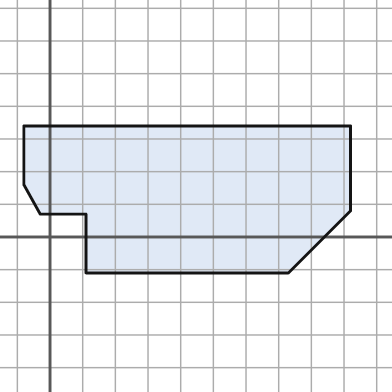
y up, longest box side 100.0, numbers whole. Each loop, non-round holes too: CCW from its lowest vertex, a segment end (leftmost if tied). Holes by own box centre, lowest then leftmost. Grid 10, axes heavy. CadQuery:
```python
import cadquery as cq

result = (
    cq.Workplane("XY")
    .moveTo(11.0, -11.0)
    .lineTo(73.0, -11.0)
    .lineTo(92.0, 8.0)
    .lineTo(92.0, 34.0)
    .lineTo(-8.0, 34.0)
    .lineTo(-8.0, 16.0)
    .lineTo(-3.0, 7.0)
    .lineTo(11.0, 7.0)
    .close()
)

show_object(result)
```